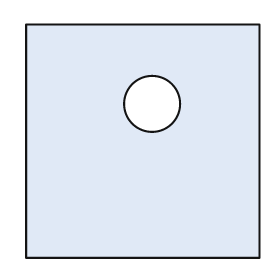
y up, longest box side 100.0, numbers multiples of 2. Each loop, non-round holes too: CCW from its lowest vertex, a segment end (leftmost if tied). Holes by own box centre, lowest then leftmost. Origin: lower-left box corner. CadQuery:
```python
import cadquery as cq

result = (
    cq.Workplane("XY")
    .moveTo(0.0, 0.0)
    .lineTo(100.0, 0.0)
    .lineTo(100.0, 100.0)
    .lineTo(0.0, 100.0)
    .close()
    .moveTo(54.0, 66.0)
    .circle(12.0)
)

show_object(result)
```